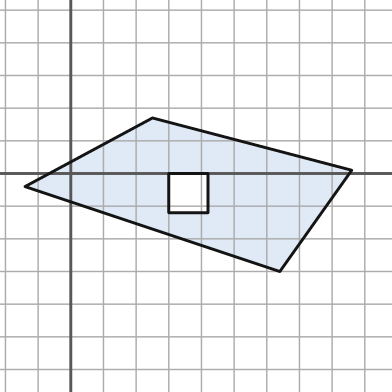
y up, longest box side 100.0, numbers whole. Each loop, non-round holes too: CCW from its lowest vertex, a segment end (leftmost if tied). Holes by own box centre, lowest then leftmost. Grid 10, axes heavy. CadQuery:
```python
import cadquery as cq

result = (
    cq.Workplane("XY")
    .moveTo(64.0, -30.0)
    .lineTo(86.0, 1.0)
    .lineTo(25.0, 17.0)
    .lineTo(-14.0, -4.0)
    .close()
    .moveTo(30.0, -12.0)
    .lineTo(42.0, -12.0)
    .lineTo(42.0, 0.0)
    .lineTo(30.0, 0.0)
    .close()
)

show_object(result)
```